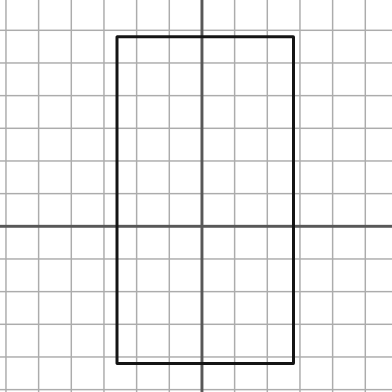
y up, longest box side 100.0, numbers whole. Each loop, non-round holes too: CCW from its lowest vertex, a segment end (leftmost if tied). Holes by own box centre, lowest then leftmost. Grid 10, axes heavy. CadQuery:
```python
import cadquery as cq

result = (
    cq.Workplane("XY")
    .moveTo(-26.0, -42.0)
    .lineTo(28.0, -42.0)
    .lineTo(28.0, 58.0)
    .lineTo(-26.0, 58.0)
    .close()
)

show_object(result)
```